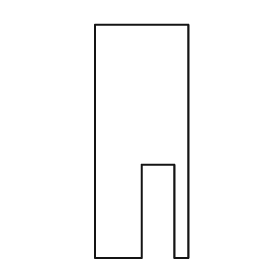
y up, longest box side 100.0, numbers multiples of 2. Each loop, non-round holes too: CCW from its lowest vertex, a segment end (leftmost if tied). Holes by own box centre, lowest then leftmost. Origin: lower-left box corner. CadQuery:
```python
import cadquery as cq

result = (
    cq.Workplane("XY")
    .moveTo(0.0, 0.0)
    .lineTo(20.0, 0.0)
    .lineTo(20.0, 40.0)
    .lineTo(34.0, 40.0)
    .lineTo(34.0, 0.0)
    .lineTo(40.0, 0.0)
    .lineTo(40.0, 100.0)
    .lineTo(0.0, 100.0)
    .close()
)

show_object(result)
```